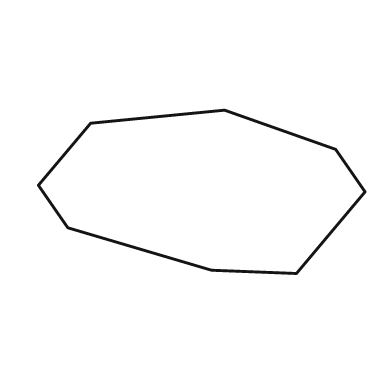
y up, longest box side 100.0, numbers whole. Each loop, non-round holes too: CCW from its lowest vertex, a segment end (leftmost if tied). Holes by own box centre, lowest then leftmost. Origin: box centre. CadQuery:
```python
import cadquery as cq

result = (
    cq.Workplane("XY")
    .moveTo(29.0, -25.0)
    .lineTo(50.0, 0.0)
    .lineTo(41.0, 13.0)
    .lineTo(7.0, 25.0)
    .lineTo(-34.0, 21.0)
    .lineTo(-50.0, 2.0)
    .lineTo(-41.0, -11.0)
    .lineTo(3.0, -24.0)
    .close()
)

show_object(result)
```